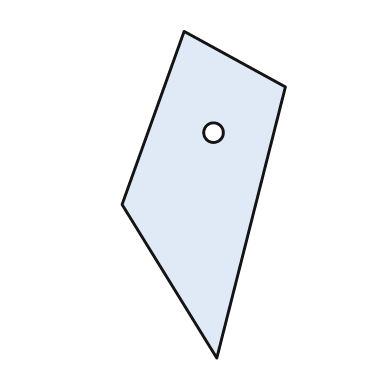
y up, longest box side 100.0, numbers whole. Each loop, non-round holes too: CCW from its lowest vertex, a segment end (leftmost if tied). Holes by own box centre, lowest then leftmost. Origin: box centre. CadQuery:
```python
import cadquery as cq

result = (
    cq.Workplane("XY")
    .moveTo(4.0, -50.0)
    .lineTo(25.0, 33.0)
    .lineTo(-6.0, 50.0)
    .lineTo(-25.0, -3.0)
    .close()
    .moveTo(3.0, 19.0)
    .circle(3.0)
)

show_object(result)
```